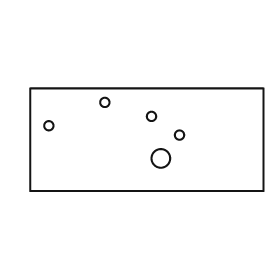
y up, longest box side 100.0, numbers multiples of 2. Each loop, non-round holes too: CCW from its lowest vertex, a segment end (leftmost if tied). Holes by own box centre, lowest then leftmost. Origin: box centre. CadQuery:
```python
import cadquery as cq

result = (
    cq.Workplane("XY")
    .moveTo(-50.0, -22.0)
    .lineTo(50.0, -22.0)
    .lineTo(50.0, 22.0)
    .lineTo(-50.0, 22.0)
    .close()
    .moveTo(6.0, -8.0)
    .circle(4.0)
    .moveTo(14.0, 2.0)
    .circle(2.0)
    .moveTo(-42.0, 6.0)
    .circle(2.0)
    .moveTo(2.0, 10.0)
    .circle(2.0)
    .moveTo(-18.0, 16.0)
    .circle(2.0)
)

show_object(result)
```